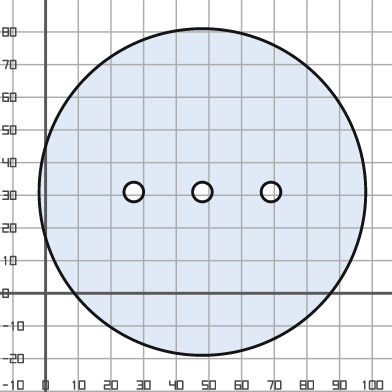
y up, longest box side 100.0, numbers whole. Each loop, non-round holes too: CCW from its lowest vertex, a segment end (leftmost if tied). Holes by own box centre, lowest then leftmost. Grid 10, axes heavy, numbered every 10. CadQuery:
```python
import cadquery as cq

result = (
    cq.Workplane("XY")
    .moveTo(48.0, 31.0)
    .circle(50.0)
    .moveTo(27.0, 31.0)
    .circle(3.0)
    .moveTo(48.0, 31.0)
    .circle(3.0)
    .moveTo(69.0, 31.0)
    .circle(3.0)
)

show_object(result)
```